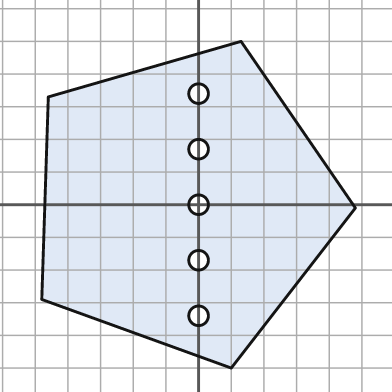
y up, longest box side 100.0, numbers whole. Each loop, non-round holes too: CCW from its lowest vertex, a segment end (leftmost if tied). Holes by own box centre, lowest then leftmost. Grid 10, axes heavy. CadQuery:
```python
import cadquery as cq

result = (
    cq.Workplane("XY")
    .moveTo(10.0, -50.0)
    .lineTo(48.0, -1.0)
    .lineTo(13.0, 50.0)
    .lineTo(-46.0, 33.0)
    .lineTo(-48.0, -29.0)
    .close()
    .moveTo(0.0, -34.0)
    .circle(3.0)
    .moveTo(0.0, -17.0)
    .circle(3.0)
    .moveTo(0.0, 0.0)
    .circle(3.0)
    .moveTo(0.0, 17.0)
    .circle(3.0)
    .moveTo(0.0, 34.0)
    .circle(3.0)
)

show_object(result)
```